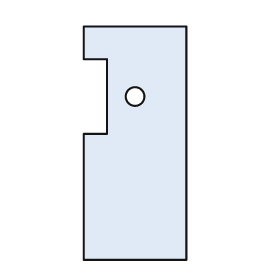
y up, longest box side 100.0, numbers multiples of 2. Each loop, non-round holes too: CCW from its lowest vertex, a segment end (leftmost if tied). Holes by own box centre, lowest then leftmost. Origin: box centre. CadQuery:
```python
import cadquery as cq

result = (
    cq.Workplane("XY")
    .moveTo(-22.0, -50.0)
    .lineTo(22.0, -50.0)
    .lineTo(22.0, 50.0)
    .lineTo(-22.0, 50.0)
    .lineTo(-22.0, 36.0)
    .lineTo(-12.0, 36.0)
    .lineTo(-12.0, 4.0)
    .lineTo(-22.0, 4.0)
    .close()
    .moveTo(0.0, 20.0)
    .circle(4.0)
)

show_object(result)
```